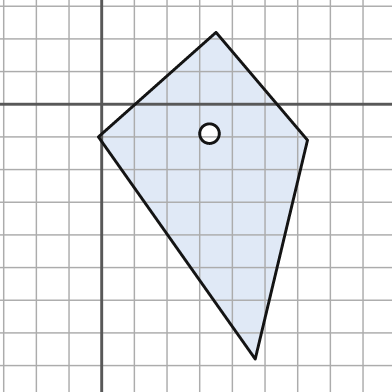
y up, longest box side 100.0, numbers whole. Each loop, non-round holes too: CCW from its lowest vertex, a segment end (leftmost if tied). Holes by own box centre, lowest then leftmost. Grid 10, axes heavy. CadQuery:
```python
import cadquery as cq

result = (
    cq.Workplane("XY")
    .moveTo(47.0, -78.0)
    .lineTo(63.0, -11.0)
    .lineTo(35.0, 22.0)
    .lineTo(-1.0, -10.0)
    .close()
    .moveTo(33.0, -9.0)
    .circle(3.0)
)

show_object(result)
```